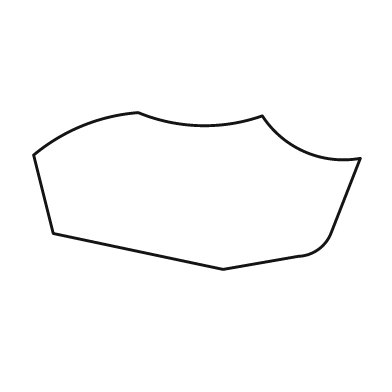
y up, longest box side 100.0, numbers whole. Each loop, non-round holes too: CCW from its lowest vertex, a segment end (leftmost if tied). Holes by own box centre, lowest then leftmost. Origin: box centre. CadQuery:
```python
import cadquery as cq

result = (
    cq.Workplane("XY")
    .moveTo(8.0, -24.0)
    .lineTo(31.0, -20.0)
    .threePointArc((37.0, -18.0), (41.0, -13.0))
    .lineTo(50.0, 10.0)
    .threePointArc((33.0, 12.0), (20.0, 23.0))
    .threePointArc((1.0, 20.0), (-18.0, 24.0))
    .threePointArc((-35.0, 20.0), (-50.0, 11.0))
    .lineTo(-44.0, -13.0)
    .close()
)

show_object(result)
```